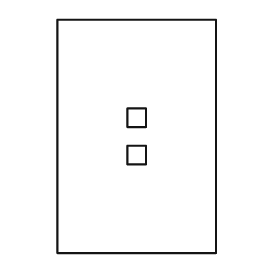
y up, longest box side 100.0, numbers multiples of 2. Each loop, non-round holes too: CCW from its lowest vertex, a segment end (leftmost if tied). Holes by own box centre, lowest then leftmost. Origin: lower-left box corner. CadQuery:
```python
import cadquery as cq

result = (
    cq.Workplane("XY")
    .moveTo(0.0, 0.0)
    .lineTo(68.0, 0.0)
    .lineTo(68.0, 100.0)
    .lineTo(0.0, 100.0)
    .close()
    .moveTo(30.0, 38.0)
    .lineTo(38.0, 38.0)
    .lineTo(38.0, 46.0)
    .lineTo(30.0, 46.0)
    .close()
    .moveTo(30.0, 54.0)
    .lineTo(38.0, 54.0)
    .lineTo(38.0, 62.0)
    .lineTo(30.0, 62.0)
    .close()
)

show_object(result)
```